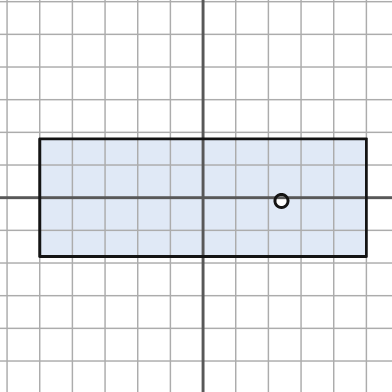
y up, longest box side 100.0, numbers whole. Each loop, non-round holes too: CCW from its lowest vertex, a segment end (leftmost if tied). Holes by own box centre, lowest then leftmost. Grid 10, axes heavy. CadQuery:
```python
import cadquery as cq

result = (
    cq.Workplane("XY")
    .moveTo(-50.0, -18.0)
    .lineTo(50.0, -18.0)
    .lineTo(50.0, 18.0)
    .lineTo(-50.0, 18.0)
    .close()
    .moveTo(24.0, -1.0)
    .circle(2.0)
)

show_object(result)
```